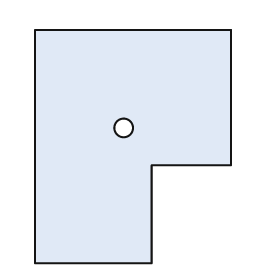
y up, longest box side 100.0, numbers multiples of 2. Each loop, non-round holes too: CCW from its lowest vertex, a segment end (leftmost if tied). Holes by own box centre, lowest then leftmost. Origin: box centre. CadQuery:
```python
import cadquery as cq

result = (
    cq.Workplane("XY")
    .moveTo(-42.0, -50.0)
    .lineTo(8.0, -50.0)
    .lineTo(8.0, -8.0)
    .lineTo(42.0, -8.0)
    .lineTo(42.0, 50.0)
    .lineTo(-42.0, 50.0)
    .close()
    .moveTo(-4.0, 8.0)
    .circle(4.0)
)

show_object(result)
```